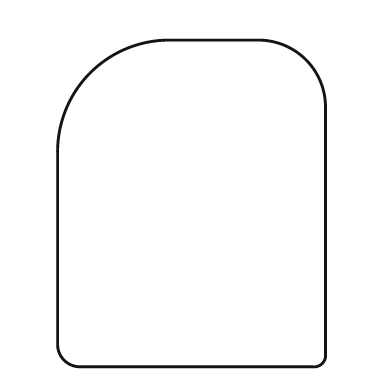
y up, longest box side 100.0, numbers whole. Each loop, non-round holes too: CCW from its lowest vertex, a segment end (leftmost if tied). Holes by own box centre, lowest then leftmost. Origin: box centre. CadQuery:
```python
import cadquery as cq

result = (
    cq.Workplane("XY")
    .moveTo(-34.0, -50.0)
    .lineTo(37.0, -50.0)
    .threePointArc((40.0, -49.0), (41.0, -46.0))
    .lineTo(41.0, 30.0)
    .threePointArc((35.0, 44.0), (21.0, 50.0))
    .lineTo(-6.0, 50.0)
    .threePointArc((-31.0, 40.0), (-41.0, 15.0))
    .lineTo(-41.0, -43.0)
    .threePointArc((-39.0, -48.0), (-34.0, -50.0))
    .close()
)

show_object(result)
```